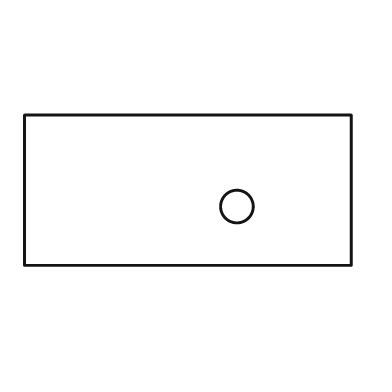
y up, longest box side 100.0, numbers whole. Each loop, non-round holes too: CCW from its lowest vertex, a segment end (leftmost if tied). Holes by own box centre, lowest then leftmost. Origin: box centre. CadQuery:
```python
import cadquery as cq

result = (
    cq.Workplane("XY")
    .moveTo(-50.0, -23.0)
    .lineTo(50.0, -23.0)
    .lineTo(50.0, 23.0)
    .lineTo(-50.0, 23.0)
    .close()
    .moveTo(15.0, -5.0)
    .circle(5.0)
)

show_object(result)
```